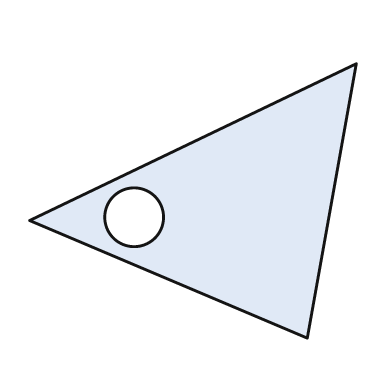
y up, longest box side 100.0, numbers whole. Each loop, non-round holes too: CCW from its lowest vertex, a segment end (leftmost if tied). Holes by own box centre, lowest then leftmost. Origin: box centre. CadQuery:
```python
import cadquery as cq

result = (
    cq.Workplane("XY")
    .moveTo(35.0, -42.0)
    .lineTo(50.0, 42.0)
    .lineTo(-50.0, -6.0)
    .close()
    .moveTo(-18.0, -5.0)
    .circle(9.0)
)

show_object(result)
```